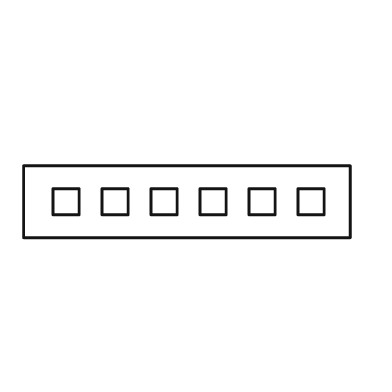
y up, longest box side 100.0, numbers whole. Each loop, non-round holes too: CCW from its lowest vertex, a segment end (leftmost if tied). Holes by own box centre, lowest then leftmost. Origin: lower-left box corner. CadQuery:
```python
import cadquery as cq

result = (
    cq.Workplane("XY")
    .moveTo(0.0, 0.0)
    .lineTo(100.0, 0.0)
    .lineTo(100.0, 22.0)
    .lineTo(0.0, 22.0)
    .close()
    .moveTo(9.0, 7.0)
    .lineTo(17.0, 7.0)
    .lineTo(17.0, 15.0)
    .lineTo(9.0, 15.0)
    .close()
    .moveTo(24.0, 7.0)
    .lineTo(32.0, 7.0)
    .lineTo(32.0, 15.0)
    .lineTo(24.0, 15.0)
    .close()
    .moveTo(39.0, 7.0)
    .lineTo(47.0, 7.0)
    .lineTo(47.0, 15.0)
    .lineTo(39.0, 15.0)
    .close()
    .moveTo(54.0, 7.0)
    .lineTo(62.0, 7.0)
    .lineTo(62.0, 15.0)
    .lineTo(54.0, 15.0)
    .close()
    .moveTo(69.0, 7.0)
    .lineTo(77.0, 7.0)
    .lineTo(77.0, 15.0)
    .lineTo(69.0, 15.0)
    .close()
    .moveTo(84.0, 7.0)
    .lineTo(92.0, 7.0)
    .lineTo(92.0, 15.0)
    .lineTo(84.0, 15.0)
    .close()
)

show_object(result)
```